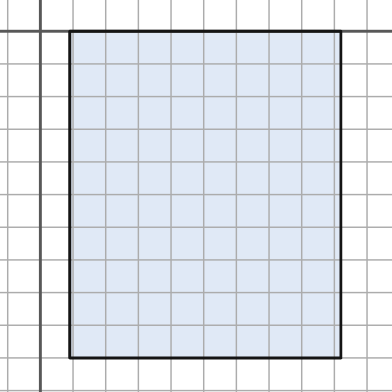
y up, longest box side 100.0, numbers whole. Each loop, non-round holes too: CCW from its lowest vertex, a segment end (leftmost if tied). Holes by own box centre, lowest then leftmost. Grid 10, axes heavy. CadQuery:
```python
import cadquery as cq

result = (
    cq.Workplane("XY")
    .moveTo(9.0, -100.0)
    .lineTo(92.0, -100.0)
    .lineTo(92.0, 0.0)
    .lineTo(9.0, 0.0)
    .close()
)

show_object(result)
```